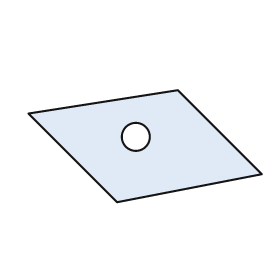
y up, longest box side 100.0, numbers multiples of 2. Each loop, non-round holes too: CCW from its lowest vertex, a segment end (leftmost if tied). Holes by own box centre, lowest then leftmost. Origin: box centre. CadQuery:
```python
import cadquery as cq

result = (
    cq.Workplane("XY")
    .moveTo(-12.0, -24.0)
    .lineTo(50.0, -12.0)
    .lineTo(14.0, 24.0)
    .lineTo(-50.0, 14.0)
    .close()
    .moveTo(-4.0, 4.0)
    .circle(6.0)
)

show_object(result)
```